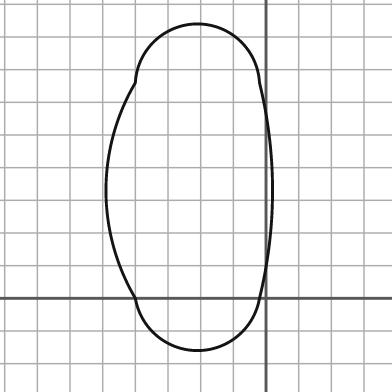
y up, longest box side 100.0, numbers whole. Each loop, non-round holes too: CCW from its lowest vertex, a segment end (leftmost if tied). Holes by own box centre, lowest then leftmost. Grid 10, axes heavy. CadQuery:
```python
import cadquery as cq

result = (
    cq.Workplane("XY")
    .moveTo(-40.0, 0.0)
    .threePointArc((-21.0, -16.0), (-2.0, 0.0))
    .threePointArc((2.0, 33.0), (-2.0, 66.0))
    .threePointArc((-21.0, 84.0), (-40.0, 66.0))
    .threePointArc((-49.0, 33.0), (-40.0, 0.0))
    .close()
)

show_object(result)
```